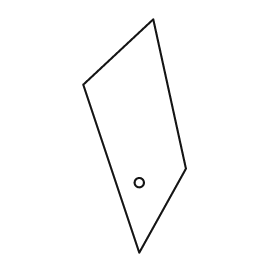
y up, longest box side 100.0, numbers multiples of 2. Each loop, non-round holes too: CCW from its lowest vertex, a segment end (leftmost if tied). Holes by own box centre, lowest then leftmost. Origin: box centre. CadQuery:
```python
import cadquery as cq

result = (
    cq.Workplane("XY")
    .moveTo(2.0, -50.0)
    .lineTo(22.0, -14.0)
    .lineTo(8.0, 50.0)
    .lineTo(-22.0, 22.0)
    .close()
    .moveTo(2.0, -20.0)
    .circle(2.0)
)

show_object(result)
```